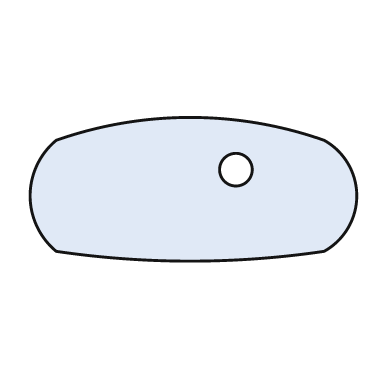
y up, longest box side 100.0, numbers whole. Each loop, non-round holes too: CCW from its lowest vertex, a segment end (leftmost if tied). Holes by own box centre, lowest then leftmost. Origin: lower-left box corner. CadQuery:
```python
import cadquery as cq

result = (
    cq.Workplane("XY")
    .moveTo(8.0, 3.0)
    .threePointArc((49.0, 0.0), (90.0, 3.0))
    .threePointArc((100.0, 20.0), (90.0, 37.0))
    .threePointArc((49.0, 44.0), (8.0, 37.0))
    .threePointArc((0.0, 20.0), (8.0, 3.0))
    .close()
    .moveTo(63.0, 28.0)
    .circle(5.0)
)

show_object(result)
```